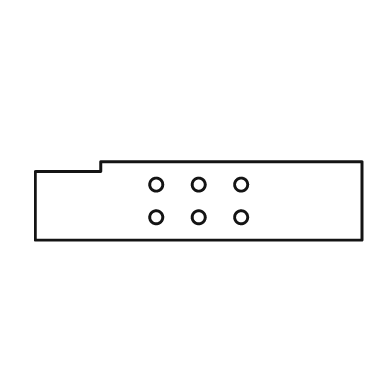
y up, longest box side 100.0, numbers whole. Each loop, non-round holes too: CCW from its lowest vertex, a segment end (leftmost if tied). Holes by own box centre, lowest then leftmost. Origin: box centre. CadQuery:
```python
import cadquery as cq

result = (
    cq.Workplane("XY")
    .moveTo(-50.0, -12.0)
    .lineTo(50.0, -12.0)
    .lineTo(50.0, 12.0)
    .lineTo(-30.0, 12.0)
    .lineTo(-30.0, 9.0)
    .lineTo(-50.0, 9.0)
    .close()
    .moveTo(-13.0, -5.0)
    .circle(2.0)
    .moveTo(0.0, -5.0)
    .circle(2.0)
    .moveTo(13.0, -5.0)
    .circle(2.0)
    .moveTo(-13.0, 5.0)
    .circle(2.0)
    .moveTo(0.0, 5.0)
    .circle(2.0)
    .moveTo(13.0, 5.0)
    .circle(2.0)
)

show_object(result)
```